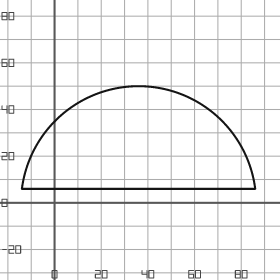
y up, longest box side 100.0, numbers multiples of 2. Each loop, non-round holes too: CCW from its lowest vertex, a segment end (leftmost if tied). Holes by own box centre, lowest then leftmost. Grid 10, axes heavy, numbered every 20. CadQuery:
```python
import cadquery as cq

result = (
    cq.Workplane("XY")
    .moveTo(-14.0, 6.0)
    .lineTo(86.0, 6.0)
    .threePointArc((36.0, 50.0), (-14.0, 6.0))
    .close()
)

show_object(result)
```